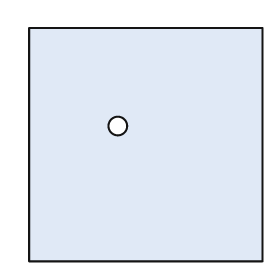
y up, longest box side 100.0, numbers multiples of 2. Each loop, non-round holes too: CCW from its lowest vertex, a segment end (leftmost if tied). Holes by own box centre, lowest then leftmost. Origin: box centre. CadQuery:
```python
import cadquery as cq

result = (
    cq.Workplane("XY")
    .moveTo(-50.0, -50.0)
    .lineTo(50.0, -50.0)
    .lineTo(50.0, 50.0)
    .lineTo(-50.0, 50.0)
    .close()
    .moveTo(-12.0, 8.0)
    .circle(4.0)
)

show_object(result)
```